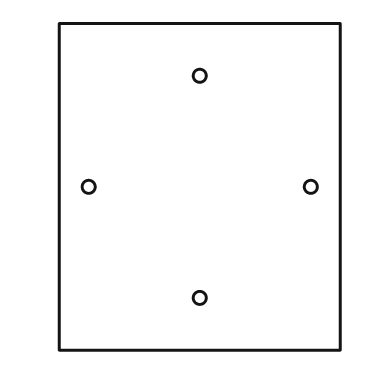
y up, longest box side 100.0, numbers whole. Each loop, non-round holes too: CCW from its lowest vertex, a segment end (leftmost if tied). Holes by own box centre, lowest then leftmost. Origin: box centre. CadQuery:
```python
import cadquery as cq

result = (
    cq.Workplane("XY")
    .moveTo(-43.0, -50.0)
    .lineTo(43.0, -50.0)
    .lineTo(43.0, 50.0)
    .lineTo(-43.0, 50.0)
    .close()
    .moveTo(0.0, -34.0)
    .circle(2.0)
    .moveTo(-34.0, 0.0)
    .circle(2.0)
    .moveTo(34.0, 0.0)
    .circle(2.0)
    .moveTo(0.0, 34.0)
    .circle(2.0)
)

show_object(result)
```